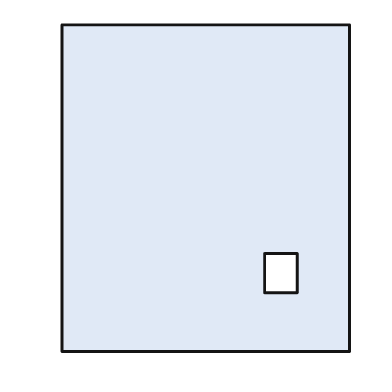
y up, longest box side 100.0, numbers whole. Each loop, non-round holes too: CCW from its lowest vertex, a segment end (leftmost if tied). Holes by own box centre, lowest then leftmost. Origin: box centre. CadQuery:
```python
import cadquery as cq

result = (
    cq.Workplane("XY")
    .moveTo(-44.0, -50.0)
    .lineTo(44.0, -50.0)
    .lineTo(44.0, 50.0)
    .lineTo(-44.0, 50.0)
    .close()
    .moveTo(18.0, -32.0)
    .lineTo(28.0, -32.0)
    .lineTo(28.0, -20.0)
    .lineTo(18.0, -20.0)
    .close()
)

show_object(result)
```